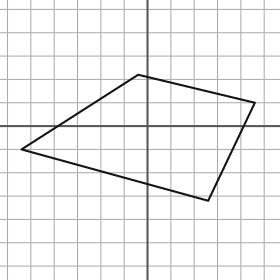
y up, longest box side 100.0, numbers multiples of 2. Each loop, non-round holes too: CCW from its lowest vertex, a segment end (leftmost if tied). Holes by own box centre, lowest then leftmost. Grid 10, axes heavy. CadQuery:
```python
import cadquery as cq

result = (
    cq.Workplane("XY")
    .moveTo(26.0, -32.0)
    .lineTo(46.0, 10.0)
    .lineTo(-4.0, 22.0)
    .lineTo(-54.0, -10.0)
    .close()
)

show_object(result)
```